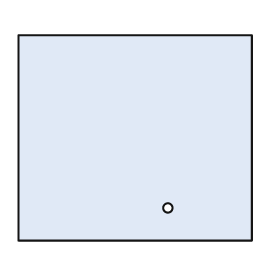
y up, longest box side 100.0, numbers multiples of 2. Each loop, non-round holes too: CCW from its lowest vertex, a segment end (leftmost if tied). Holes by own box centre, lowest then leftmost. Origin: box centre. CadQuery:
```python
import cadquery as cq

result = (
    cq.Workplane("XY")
    .moveTo(-50.0, -44.0)
    .lineTo(50.0, -44.0)
    .lineTo(50.0, 44.0)
    .lineTo(-50.0, 44.0)
    .close()
    .moveTo(14.0, -30.0)
    .circle(2.0)
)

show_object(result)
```